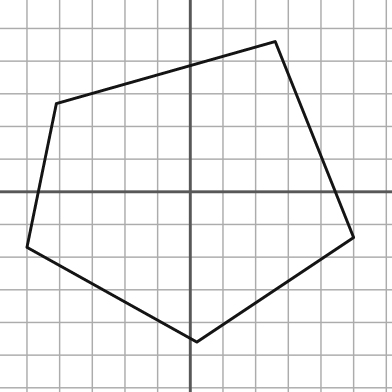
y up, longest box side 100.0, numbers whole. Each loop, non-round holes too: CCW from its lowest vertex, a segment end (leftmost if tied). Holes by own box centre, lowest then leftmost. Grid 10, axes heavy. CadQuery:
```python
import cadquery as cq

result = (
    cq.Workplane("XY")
    .moveTo(2.0, -46.0)
    .lineTo(50.0, -14.0)
    .lineTo(26.0, 46.0)
    .lineTo(-41.0, 27.0)
    .lineTo(-50.0, -17.0)
    .close()
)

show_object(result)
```